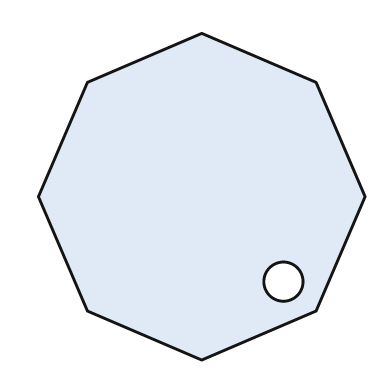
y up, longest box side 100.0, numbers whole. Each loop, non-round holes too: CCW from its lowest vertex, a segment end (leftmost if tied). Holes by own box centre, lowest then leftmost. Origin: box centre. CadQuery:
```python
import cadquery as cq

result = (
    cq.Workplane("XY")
    .moveTo(0.0, -50.0)
    .lineTo(35.0, -35.0)
    .lineTo(50.0, 0.0)
    .lineTo(35.0, 35.0)
    .lineTo(0.0, 50.0)
    .lineTo(-35.0, 35.0)
    .lineTo(-50.0, 0.0)
    .lineTo(-35.0, -35.0)
    .close()
    .moveTo(25.0, -26.0)
    .circle(6.0)
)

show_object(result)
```